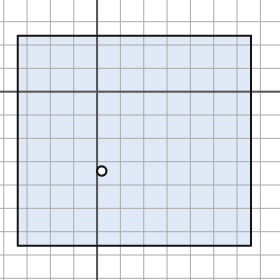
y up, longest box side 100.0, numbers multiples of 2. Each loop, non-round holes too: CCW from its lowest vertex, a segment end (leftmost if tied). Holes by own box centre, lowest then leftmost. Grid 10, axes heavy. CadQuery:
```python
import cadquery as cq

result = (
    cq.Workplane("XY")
    .moveTo(-34.0, -66.0)
    .lineTo(66.0, -66.0)
    .lineTo(66.0, 24.0)
    .lineTo(-34.0, 24.0)
    .close()
    .moveTo(2.0, -34.0)
    .circle(2.0)
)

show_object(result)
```